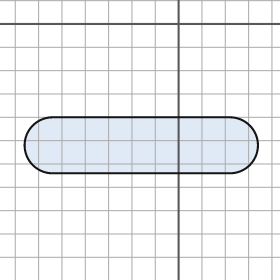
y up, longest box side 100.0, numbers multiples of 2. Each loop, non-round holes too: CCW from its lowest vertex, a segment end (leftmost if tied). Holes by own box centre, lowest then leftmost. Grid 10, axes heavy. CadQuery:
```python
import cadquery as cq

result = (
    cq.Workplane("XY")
    .moveTo(-54.0, -64.0)
    .lineTo(22.0, -64.0)
    .threePointArc((34.0, -52.0), (22.0, -40.0))
    .lineTo(-54.0, -40.0)
    .threePointArc((-66.0, -52.0), (-54.0, -64.0))
    .close()
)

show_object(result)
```